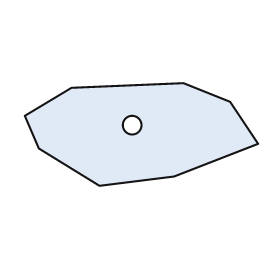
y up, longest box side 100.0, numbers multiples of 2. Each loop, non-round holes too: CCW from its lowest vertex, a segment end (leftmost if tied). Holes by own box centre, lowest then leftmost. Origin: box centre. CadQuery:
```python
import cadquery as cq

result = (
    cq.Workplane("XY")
    .moveTo(-18.0, -22.0)
    .lineTo(14.0, -18.0)
    .lineTo(50.0, -4.0)
    .lineTo(38.0, 14.0)
    .lineTo(18.0, 22.0)
    .lineTo(-30.0, 20.0)
    .lineTo(-50.0, 8.0)
    .lineTo(-44.0, -6.0)
    .close()
    .moveTo(-4.0, 4.0)
    .circle(4.0)
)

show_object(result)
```